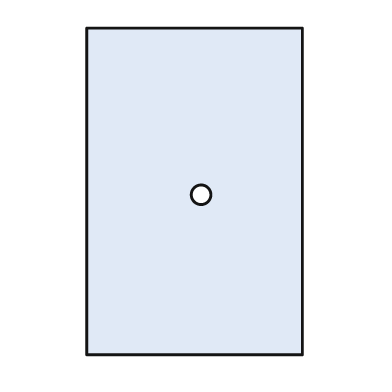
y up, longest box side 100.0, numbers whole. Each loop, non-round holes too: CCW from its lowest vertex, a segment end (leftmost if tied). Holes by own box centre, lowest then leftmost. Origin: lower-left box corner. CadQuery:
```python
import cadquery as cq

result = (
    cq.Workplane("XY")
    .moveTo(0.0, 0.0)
    .lineTo(66.0, 0.0)
    .lineTo(66.0, 100.0)
    .lineTo(0.0, 100.0)
    .close()
    .moveTo(35.0, 49.0)
    .circle(3.0)
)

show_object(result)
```